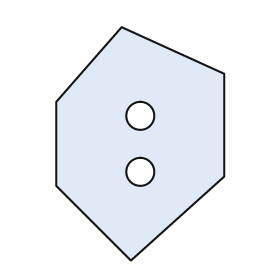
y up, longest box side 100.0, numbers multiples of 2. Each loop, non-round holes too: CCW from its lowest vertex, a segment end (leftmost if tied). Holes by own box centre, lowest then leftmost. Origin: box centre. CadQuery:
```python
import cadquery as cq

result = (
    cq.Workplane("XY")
    .moveTo(-4.0, -50.0)
    .lineTo(36.0, -14.0)
    .lineTo(36.0, 30.0)
    .lineTo(-8.0, 50.0)
    .lineTo(-36.0, 18.0)
    .lineTo(-36.0, -18.0)
    .close()
    .moveTo(0.0, -12.0)
    .circle(6.0)
    .moveTo(0.0, 12.0)
    .circle(6.0)
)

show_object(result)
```